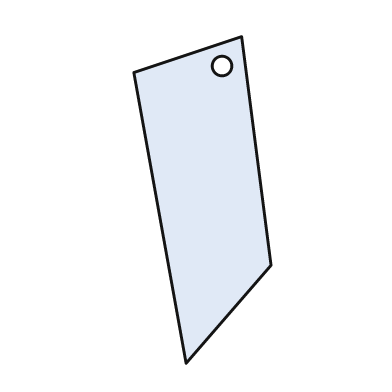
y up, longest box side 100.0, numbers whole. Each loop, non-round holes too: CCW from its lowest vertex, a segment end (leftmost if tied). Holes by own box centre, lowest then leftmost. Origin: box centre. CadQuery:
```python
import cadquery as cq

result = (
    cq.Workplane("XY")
    .moveTo(-5.0, -50.0)
    .lineTo(21.0, -20.0)
    .lineTo(12.0, 50.0)
    .lineTo(-21.0, 39.0)
    .close()
    .moveTo(6.0, 41.0)
    .circle(3.0)
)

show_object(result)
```